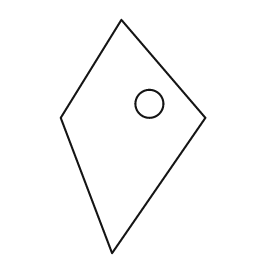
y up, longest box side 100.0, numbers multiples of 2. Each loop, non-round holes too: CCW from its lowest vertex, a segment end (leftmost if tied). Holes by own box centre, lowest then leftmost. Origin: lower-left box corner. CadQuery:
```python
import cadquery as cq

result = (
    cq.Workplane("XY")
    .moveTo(22.0, 0.0)
    .lineTo(62.0, 58.0)
    .lineTo(26.0, 100.0)
    .lineTo(0.0, 58.0)
    .close()
    .moveTo(38.0, 64.0)
    .circle(6.0)
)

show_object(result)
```